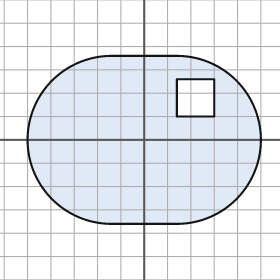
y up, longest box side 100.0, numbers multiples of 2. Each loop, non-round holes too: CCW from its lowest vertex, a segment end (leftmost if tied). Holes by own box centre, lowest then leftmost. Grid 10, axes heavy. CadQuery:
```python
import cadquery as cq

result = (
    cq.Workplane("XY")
    .moveTo(-14.0, -36.0)
    .lineTo(14.0, -36.0)
    .threePointArc((50.0, 0.0), (14.0, 36.0))
    .lineTo(-14.0, 36.0)
    .threePointArc((-50.0, 0.0), (-14.0, -36.0))
    .close()
    .moveTo(14.0, 10.0)
    .lineTo(30.0, 10.0)
    .lineTo(30.0, 26.0)
    .lineTo(14.0, 26.0)
    .close()
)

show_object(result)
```